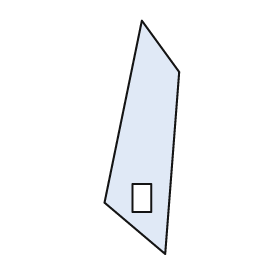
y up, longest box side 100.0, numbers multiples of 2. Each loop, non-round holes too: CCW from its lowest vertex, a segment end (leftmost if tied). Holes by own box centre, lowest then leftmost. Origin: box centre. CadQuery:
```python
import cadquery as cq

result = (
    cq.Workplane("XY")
    .moveTo(10.0, -50.0)
    .lineTo(16.0, 28.0)
    .lineTo(0.0, 50.0)
    .lineTo(-16.0, -28.0)
    .close()
    .moveTo(-4.0, -32.0)
    .lineTo(4.0, -32.0)
    .lineTo(4.0, -20.0)
    .lineTo(-4.0, -20.0)
    .close()
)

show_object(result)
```